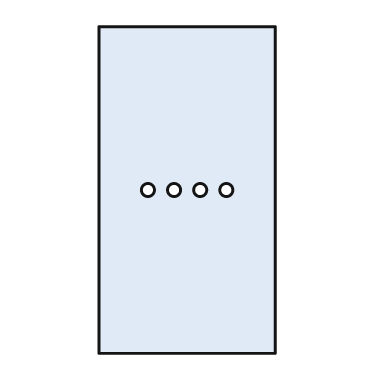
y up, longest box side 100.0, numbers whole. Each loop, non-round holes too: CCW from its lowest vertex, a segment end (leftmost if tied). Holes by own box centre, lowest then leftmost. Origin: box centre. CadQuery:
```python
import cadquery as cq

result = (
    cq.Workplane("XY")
    .moveTo(-27.0, -50.0)
    .lineTo(27.0, -50.0)
    .lineTo(27.0, 50.0)
    .lineTo(-27.0, 50.0)
    .close()
    .moveTo(-12.0, 0.0)
    .circle(2.0)
    .moveTo(-4.0, 0.0)
    .circle(2.0)
    .moveTo(4.0, 0.0)
    .circle(2.0)
    .moveTo(12.0, 0.0)
    .circle(2.0)
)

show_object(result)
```